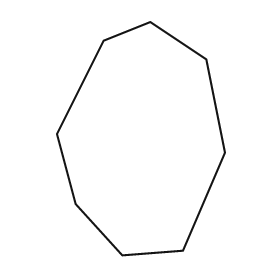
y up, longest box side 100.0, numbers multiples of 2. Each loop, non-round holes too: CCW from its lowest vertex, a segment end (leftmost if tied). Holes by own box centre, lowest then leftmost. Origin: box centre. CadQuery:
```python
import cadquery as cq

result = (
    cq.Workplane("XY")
    .moveTo(-8.0, -50.0)
    .lineTo(18.0, -48.0)
    .lineTo(36.0, -6.0)
    .lineTo(28.0, 34.0)
    .lineTo(4.0, 50.0)
    .lineTo(-16.0, 42.0)
    .lineTo(-36.0, 2.0)
    .lineTo(-28.0, -28.0)
    .close()
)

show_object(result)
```